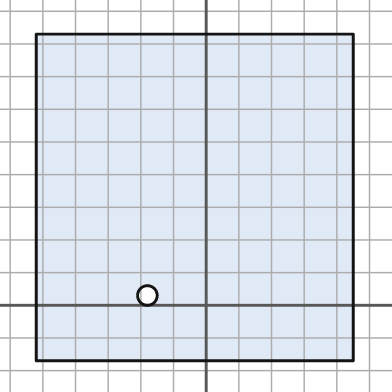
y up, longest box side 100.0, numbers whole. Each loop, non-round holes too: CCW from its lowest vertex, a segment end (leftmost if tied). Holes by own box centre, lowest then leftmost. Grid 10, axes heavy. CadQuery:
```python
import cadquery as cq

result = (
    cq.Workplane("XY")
    .moveTo(-52.0, -17.0)
    .lineTo(45.0, -17.0)
    .lineTo(45.0, 83.0)
    .lineTo(-52.0, 83.0)
    .close()
    .moveTo(-18.0, 3.0)
    .circle(3.0)
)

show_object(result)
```